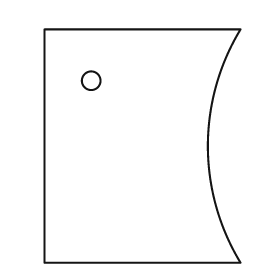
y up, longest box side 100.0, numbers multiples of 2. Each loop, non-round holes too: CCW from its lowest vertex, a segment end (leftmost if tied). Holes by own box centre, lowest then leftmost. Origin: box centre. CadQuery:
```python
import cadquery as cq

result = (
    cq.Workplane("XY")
    .moveTo(-42.0, -50.0)
    .lineTo(42.0, -50.0)
    .threePointArc((28.0, 0.0), (42.0, 50.0))
    .lineTo(-42.0, 50.0)
    .close()
    .moveTo(-22.0, 28.0)
    .circle(4.0)
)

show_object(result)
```